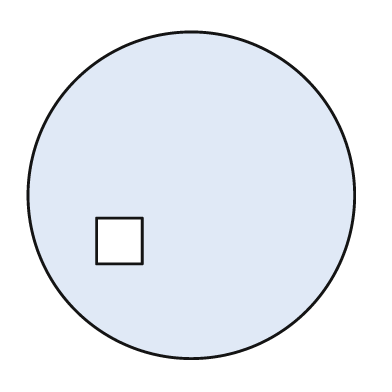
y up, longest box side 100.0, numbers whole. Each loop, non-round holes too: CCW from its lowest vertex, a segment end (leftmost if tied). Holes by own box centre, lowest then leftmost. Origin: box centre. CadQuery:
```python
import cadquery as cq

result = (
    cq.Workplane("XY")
    .moveTo(0.0, 0.0)
    .circle(50.0)
    .moveTo(-29.0, -21.0)
    .lineTo(-15.0, -21.0)
    .lineTo(-15.0, -7.0)
    .lineTo(-29.0, -7.0)
    .close()
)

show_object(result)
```